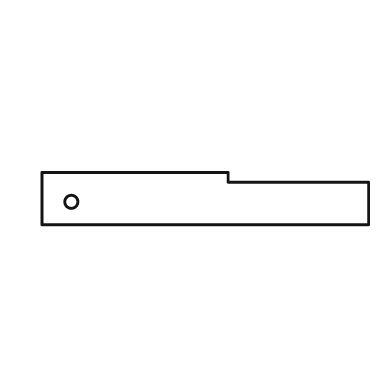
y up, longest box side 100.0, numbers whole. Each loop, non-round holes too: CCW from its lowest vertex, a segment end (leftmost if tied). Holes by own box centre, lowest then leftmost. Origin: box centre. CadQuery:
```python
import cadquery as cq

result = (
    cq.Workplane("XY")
    .moveTo(-50.0, -8.0)
    .lineTo(50.0, -8.0)
    .lineTo(50.0, 5.0)
    .lineTo(7.0, 5.0)
    .lineTo(7.0, 8.0)
    .lineTo(-50.0, 8.0)
    .close()
    .moveTo(-41.0, -1.0)
    .circle(2.0)
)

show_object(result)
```